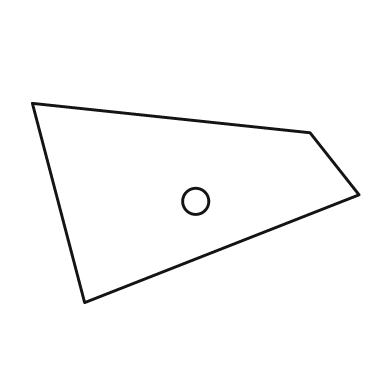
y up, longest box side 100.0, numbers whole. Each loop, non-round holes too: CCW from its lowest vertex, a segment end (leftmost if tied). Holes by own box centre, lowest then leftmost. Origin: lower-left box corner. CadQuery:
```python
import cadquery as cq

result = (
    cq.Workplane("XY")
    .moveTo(16.0, 0.0)
    .lineTo(100.0, 33.0)
    .lineTo(85.0, 52.0)
    .lineTo(0.0, 61.0)
    .close()
    .moveTo(50.0, 31.0)
    .circle(4.0)
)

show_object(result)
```